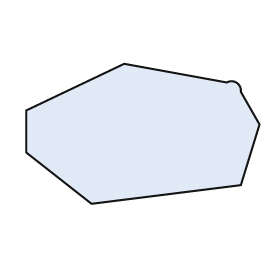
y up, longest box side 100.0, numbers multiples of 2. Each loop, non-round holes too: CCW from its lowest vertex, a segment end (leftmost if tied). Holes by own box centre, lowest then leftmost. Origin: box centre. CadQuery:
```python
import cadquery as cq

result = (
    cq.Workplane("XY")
    .moveTo(-22.0, -30.0)
    .lineTo(42.0, -22.0)
    .lineTo(50.0, 4.0)
    .lineTo(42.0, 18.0)
    .threePointArc((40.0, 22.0), (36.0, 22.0))
    .lineTo(-8.0, 30.0)
    .lineTo(-50.0, 10.0)
    .lineTo(-50.0, -8.0)
    .close()
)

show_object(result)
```